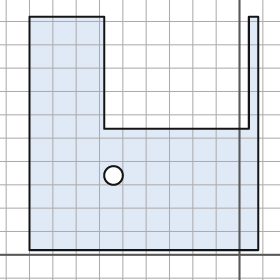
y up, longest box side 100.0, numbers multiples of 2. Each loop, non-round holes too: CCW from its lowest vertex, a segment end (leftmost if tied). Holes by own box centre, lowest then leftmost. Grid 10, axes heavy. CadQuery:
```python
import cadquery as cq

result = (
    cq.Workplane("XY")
    .moveTo(-90.0, 2.0)
    .lineTo(8.0, 2.0)
    .lineTo(8.0, 102.0)
    .lineTo(4.0, 102.0)
    .lineTo(4.0, 54.0)
    .lineTo(-58.0, 54.0)
    .lineTo(-58.0, 102.0)
    .lineTo(-90.0, 102.0)
    .close()
    .moveTo(-54.0, 34.0)
    .circle(4.0)
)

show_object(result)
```